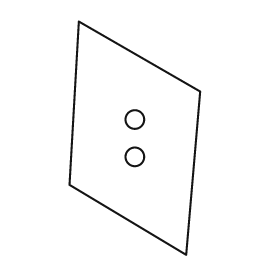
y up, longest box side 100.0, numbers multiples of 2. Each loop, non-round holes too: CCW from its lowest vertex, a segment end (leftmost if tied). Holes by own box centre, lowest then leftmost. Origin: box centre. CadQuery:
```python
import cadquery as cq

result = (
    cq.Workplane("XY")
    .moveTo(22.0, -50.0)
    .lineTo(28.0, 20.0)
    .lineTo(-24.0, 50.0)
    .lineTo(-28.0, -20.0)
    .close()
    .moveTo(0.0, -8.0)
    .circle(4.0)
    .moveTo(0.0, 8.0)
    .circle(4.0)
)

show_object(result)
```